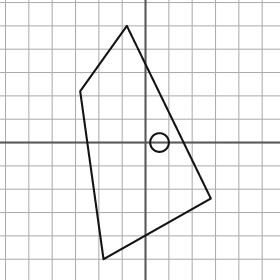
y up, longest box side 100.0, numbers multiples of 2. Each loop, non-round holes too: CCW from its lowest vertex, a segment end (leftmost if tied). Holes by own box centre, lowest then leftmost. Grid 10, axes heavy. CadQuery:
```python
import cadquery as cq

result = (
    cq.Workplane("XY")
    .moveTo(-18.0, -50.0)
    .lineTo(28.0, -24.0)
    .lineTo(-8.0, 50.0)
    .lineTo(-28.0, 22.0)
    .close()
    .moveTo(6.0, 0.0)
    .circle(4.0)
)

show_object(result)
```